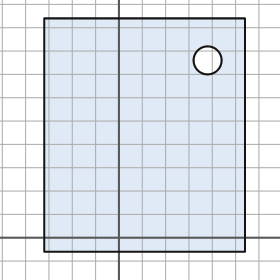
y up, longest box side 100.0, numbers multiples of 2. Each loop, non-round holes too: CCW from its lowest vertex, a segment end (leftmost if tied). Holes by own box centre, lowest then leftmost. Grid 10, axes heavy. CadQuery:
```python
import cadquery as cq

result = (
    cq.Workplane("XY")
    .moveTo(-32.0, -6.0)
    .lineTo(54.0, -6.0)
    .lineTo(54.0, 94.0)
    .lineTo(-32.0, 94.0)
    .close()
    .moveTo(38.0, 76.0)
    .circle(6.0)
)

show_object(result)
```